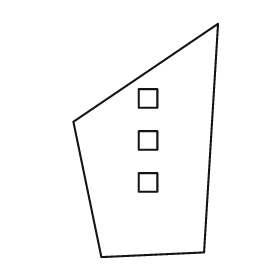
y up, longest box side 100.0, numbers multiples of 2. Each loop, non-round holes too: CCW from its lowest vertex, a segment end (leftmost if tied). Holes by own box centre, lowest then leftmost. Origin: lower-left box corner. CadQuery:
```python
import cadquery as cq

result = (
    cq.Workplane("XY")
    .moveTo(12.0, 0.0)
    .lineTo(56.0, 2.0)
    .lineTo(62.0, 100.0)
    .lineTo(0.0, 58.0)
    .close()
    .moveTo(28.0, 28.0)
    .lineTo(36.0, 28.0)
    .lineTo(36.0, 36.0)
    .lineTo(28.0, 36.0)
    .close()
    .moveTo(28.0, 46.0)
    .lineTo(36.0, 46.0)
    .lineTo(36.0, 54.0)
    .lineTo(28.0, 54.0)
    .close()
    .moveTo(28.0, 64.0)
    .lineTo(36.0, 64.0)
    .lineTo(36.0, 72.0)
    .lineTo(28.0, 72.0)
    .close()
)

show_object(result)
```